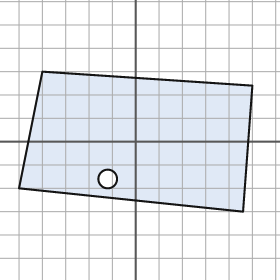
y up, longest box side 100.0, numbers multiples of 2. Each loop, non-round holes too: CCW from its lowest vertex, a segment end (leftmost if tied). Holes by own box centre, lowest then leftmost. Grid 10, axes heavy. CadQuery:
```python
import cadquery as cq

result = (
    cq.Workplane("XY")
    .moveTo(46.0, -30.0)
    .lineTo(50.0, 24.0)
    .lineTo(-40.0, 30.0)
    .lineTo(-50.0, -20.0)
    .close()
    .moveTo(-12.0, -16.0)
    .circle(4.0)
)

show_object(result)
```